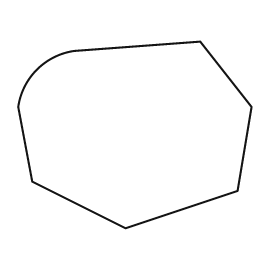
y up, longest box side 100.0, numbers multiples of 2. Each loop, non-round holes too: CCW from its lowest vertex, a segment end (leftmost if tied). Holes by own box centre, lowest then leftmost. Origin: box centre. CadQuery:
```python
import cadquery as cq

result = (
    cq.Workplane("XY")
    .moveTo(-4.0, -40.0)
    .lineTo(44.0, -24.0)
    .lineTo(50.0, 12.0)
    .lineTo(28.0, 40.0)
    .lineTo(-26.0, 36.0)
    .threePointArc((-42.0, 28.0), (-50.0, 12.0))
    .lineTo(-44.0, -20.0)
    .close()
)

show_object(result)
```